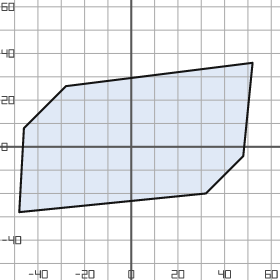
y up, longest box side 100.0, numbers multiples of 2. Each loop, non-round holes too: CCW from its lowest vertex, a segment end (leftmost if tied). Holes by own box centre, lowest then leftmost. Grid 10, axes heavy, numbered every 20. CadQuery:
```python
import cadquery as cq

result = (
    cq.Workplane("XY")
    .moveTo(-48.0, -28.0)
    .lineTo(32.0, -20.0)
    .lineTo(48.0, -4.0)
    .lineTo(52.0, 36.0)
    .lineTo(-28.0, 26.0)
    .lineTo(-46.0, 8.0)
    .close()
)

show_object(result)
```